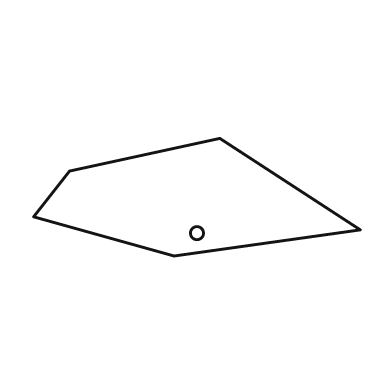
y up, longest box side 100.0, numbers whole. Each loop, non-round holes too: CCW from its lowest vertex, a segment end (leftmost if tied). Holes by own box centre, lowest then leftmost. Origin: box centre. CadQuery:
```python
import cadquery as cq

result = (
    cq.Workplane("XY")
    .moveTo(-7.0, -18.0)
    .lineTo(50.0, -10.0)
    .lineTo(7.0, 18.0)
    .lineTo(-39.0, 8.0)
    .lineTo(-50.0, -6.0)
    .close()
    .moveTo(0.0, -11.0)
    .circle(2.0)
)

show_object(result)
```